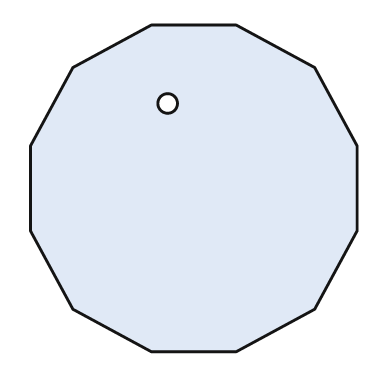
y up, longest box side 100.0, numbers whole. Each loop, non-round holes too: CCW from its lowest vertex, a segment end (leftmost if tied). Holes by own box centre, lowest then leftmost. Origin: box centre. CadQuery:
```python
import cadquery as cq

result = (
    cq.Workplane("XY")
    .moveTo(-13.0, -50.0)
    .lineTo(13.0, -50.0)
    .lineTo(37.0, -37.0)
    .lineTo(50.0, -13.0)
    .lineTo(50.0, 13.0)
    .lineTo(37.0, 37.0)
    .lineTo(13.0, 50.0)
    .lineTo(-13.0, 50.0)
    .lineTo(-37.0, 37.0)
    .lineTo(-50.0, 13.0)
    .lineTo(-50.0, -13.0)
    .lineTo(-37.0, -37.0)
    .close()
    .moveTo(-8.0, 26.0)
    .circle(3.0)
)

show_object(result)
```